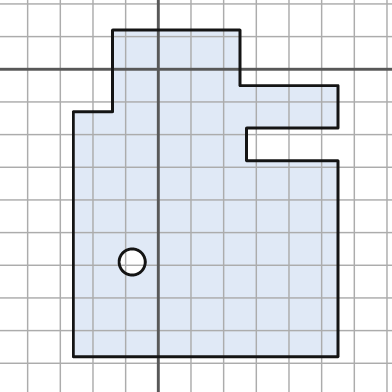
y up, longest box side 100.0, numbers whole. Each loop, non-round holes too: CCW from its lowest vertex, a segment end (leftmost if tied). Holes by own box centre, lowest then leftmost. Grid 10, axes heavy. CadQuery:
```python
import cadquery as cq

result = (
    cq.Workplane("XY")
    .moveTo(-26.0, -88.0)
    .lineTo(55.0, -88.0)
    .lineTo(55.0, -28.0)
    .lineTo(27.0, -28.0)
    .lineTo(27.0, -18.0)
    .lineTo(55.0, -18.0)
    .lineTo(55.0, -5.0)
    .lineTo(25.0, -5.0)
    .lineTo(25.0, 12.0)
    .lineTo(-14.0, 12.0)
    .lineTo(-14.0, -13.0)
    .lineTo(-26.0, -13.0)
    .close()
    .moveTo(-8.0, -59.0)
    .circle(4.0)
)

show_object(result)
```